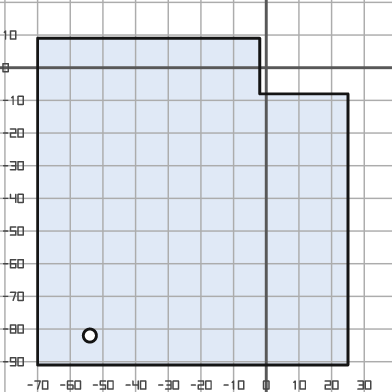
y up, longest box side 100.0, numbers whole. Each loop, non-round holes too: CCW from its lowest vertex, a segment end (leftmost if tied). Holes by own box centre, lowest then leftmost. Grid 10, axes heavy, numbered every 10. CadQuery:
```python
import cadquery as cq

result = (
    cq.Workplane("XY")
    .moveTo(-70.0, -91.0)
    .lineTo(25.0, -91.0)
    .lineTo(25.0, -8.0)
    .lineTo(-2.0, -8.0)
    .lineTo(-2.0, 9.0)
    .lineTo(-70.0, 9.0)
    .close()
    .moveTo(-54.0, -82.0)
    .circle(2.0)
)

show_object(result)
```